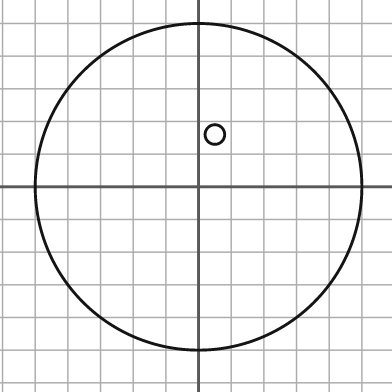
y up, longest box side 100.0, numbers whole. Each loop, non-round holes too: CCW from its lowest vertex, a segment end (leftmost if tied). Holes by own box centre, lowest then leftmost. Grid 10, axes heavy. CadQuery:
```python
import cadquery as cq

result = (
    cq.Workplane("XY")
    .moveTo(0.0, 0.0)
    .circle(50.0)
    .moveTo(5.0, 16.0)
    .circle(3.0)
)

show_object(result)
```